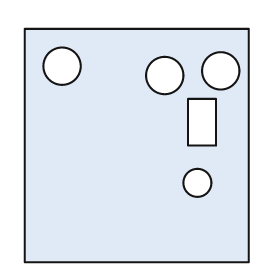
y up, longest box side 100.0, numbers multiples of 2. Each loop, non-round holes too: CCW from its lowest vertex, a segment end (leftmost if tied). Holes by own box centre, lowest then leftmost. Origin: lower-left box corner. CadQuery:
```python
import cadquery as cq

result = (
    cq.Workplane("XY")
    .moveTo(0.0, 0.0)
    .lineTo(96.0, 0.0)
    .lineTo(96.0, 100.0)
    .lineTo(0.0, 100.0)
    .close()
    .moveTo(74.0, 34.0)
    .circle(6.0)
    .moveTo(70.0, 50.0)
    .lineTo(82.0, 50.0)
    .lineTo(82.0, 70.0)
    .lineTo(70.0, 70.0)
    .close()
    .moveTo(60.0, 80.0)
    .circle(8.0)
    .moveTo(84.0, 82.0)
    .circle(8.0)
    .moveTo(16.0, 84.0)
    .circle(8.0)
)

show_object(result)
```